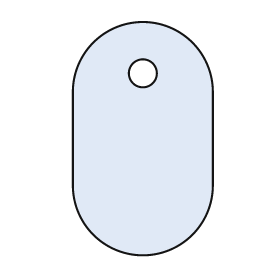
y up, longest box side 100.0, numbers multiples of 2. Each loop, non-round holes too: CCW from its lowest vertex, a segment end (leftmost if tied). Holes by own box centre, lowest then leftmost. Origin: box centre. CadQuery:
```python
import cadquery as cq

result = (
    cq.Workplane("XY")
    .moveTo(-30.0, -20.0)
    .threePointArc((0.0, -50.0), (30.0, -20.0))
    .lineTo(30.0, 20.0)
    .threePointArc((0.0, 50.0), (-30.0, 20.0))
    .close()
    .moveTo(0.0, 28.0)
    .circle(6.0)
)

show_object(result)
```